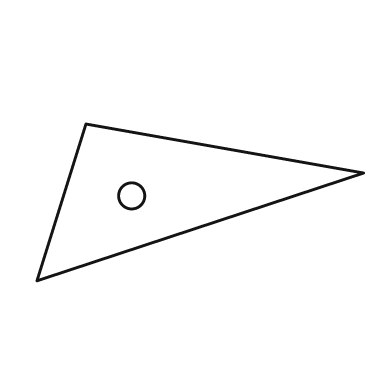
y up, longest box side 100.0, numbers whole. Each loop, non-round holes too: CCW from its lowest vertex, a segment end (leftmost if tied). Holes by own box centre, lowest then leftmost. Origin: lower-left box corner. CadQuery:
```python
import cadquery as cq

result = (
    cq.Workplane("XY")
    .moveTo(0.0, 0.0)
    .lineTo(100.0, 33.0)
    .lineTo(15.0, 48.0)
    .close()
    .moveTo(29.0, 26.0)
    .circle(4.0)
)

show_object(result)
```